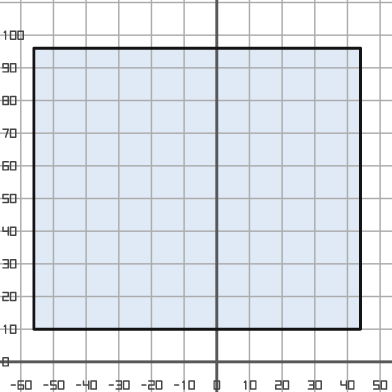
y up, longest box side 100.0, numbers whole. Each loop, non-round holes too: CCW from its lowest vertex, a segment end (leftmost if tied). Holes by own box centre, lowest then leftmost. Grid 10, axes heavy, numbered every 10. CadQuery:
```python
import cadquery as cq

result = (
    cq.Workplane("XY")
    .moveTo(-56.0, 10.0)
    .lineTo(44.0, 10.0)
    .lineTo(44.0, 96.0)
    .lineTo(-56.0, 96.0)
    .close()
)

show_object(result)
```